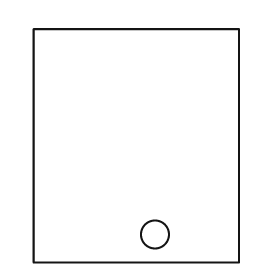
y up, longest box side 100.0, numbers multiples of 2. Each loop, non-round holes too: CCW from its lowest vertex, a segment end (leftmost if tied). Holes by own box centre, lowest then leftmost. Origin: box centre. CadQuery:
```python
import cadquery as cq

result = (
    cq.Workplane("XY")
    .moveTo(-44.0, -50.0)
    .lineTo(44.0, -50.0)
    .lineTo(44.0, 50.0)
    .lineTo(-44.0, 50.0)
    .close()
    .moveTo(8.0, -38.0)
    .circle(6.0)
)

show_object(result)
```